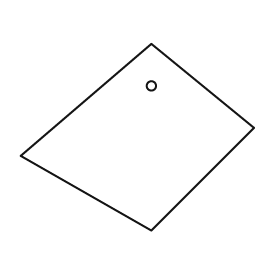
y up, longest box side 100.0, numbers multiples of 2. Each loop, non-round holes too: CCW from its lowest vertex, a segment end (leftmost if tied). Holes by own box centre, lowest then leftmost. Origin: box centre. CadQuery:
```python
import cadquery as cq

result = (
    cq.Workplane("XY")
    .moveTo(6.0, -40.0)
    .lineTo(50.0, 4.0)
    .lineTo(6.0, 40.0)
    .lineTo(-50.0, -8.0)
    .close()
    .moveTo(6.0, 22.0)
    .circle(2.0)
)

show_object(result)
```